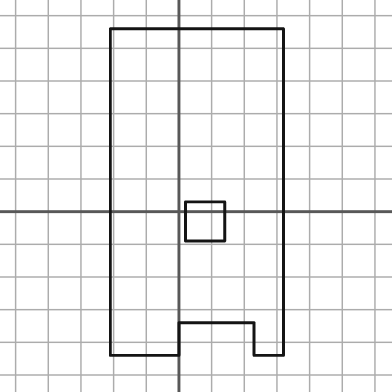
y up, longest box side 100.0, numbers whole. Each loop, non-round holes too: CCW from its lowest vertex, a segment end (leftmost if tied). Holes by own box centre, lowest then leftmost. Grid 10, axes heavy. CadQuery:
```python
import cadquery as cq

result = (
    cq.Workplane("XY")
    .moveTo(-21.0, -44.0)
    .lineTo(0.0, -44.0)
    .lineTo(0.0, -34.0)
    .lineTo(23.0, -34.0)
    .lineTo(23.0, -44.0)
    .lineTo(32.0, -44.0)
    .lineTo(32.0, 56.0)
    .lineTo(-21.0, 56.0)
    .close()
    .moveTo(2.0, -9.0)
    .lineTo(14.0, -9.0)
    .lineTo(14.0, 3.0)
    .lineTo(2.0, 3.0)
    .close()
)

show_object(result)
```